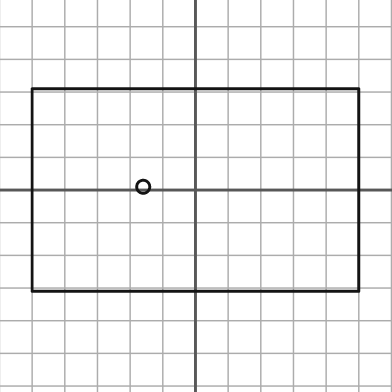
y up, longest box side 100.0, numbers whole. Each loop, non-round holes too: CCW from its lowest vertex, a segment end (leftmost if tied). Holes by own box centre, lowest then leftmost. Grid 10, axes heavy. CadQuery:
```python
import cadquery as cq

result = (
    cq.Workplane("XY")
    .moveTo(-50.0, -31.0)
    .lineTo(50.0, -31.0)
    .lineTo(50.0, 31.0)
    .lineTo(-50.0, 31.0)
    .close()
    .moveTo(-16.0, 1.0)
    .circle(2.0)
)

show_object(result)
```